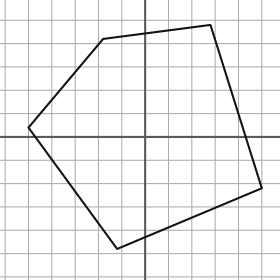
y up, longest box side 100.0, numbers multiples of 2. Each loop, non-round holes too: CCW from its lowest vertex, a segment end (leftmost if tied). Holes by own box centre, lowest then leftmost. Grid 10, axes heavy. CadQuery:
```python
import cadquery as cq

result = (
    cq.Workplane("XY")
    .moveTo(-12.0, -48.0)
    .lineTo(50.0, -22.0)
    .lineTo(28.0, 48.0)
    .lineTo(-18.0, 42.0)
    .lineTo(-50.0, 4.0)
    .close()
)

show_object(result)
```